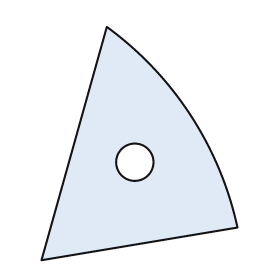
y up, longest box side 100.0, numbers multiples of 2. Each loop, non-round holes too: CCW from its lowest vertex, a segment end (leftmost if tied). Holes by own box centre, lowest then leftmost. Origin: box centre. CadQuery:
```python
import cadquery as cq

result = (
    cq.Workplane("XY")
    .moveTo(-42.0, -50.0)
    .lineTo(42.0, -36.0)
    .threePointArc((22.0, 12.0), (-14.0, 50.0))
    .close()
    .moveTo(-2.0, -8.0)
    .circle(8.0)
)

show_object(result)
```